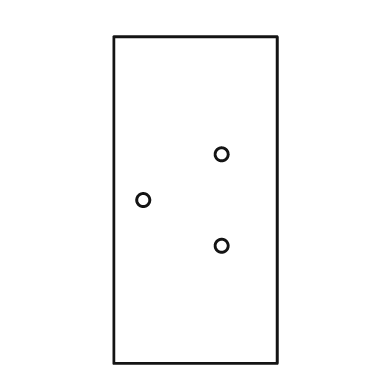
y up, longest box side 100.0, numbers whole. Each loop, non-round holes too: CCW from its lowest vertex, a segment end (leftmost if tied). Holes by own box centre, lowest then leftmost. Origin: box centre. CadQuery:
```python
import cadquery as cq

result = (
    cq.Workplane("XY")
    .moveTo(-25.0, -50.0)
    .lineTo(25.0, -50.0)
    .lineTo(25.0, 50.0)
    .lineTo(-25.0, 50.0)
    .close()
    .moveTo(8.0, -14.0)
    .circle(2.0)
    .moveTo(-16.0, 0.0)
    .circle(2.0)
    .moveTo(8.0, 14.0)
    .circle(2.0)
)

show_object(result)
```